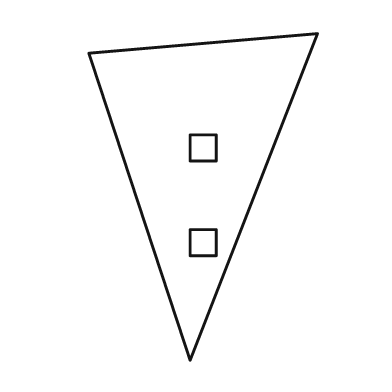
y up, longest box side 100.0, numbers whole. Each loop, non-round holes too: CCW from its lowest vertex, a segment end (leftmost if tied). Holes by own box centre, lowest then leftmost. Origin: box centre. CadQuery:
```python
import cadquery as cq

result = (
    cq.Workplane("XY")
    .moveTo(-4.0, -50.0)
    .lineTo(35.0, 50.0)
    .lineTo(-35.0, 44.0)
    .close()
    .moveTo(-4.0, -18.0)
    .lineTo(4.0, -18.0)
    .lineTo(4.0, -10.0)
    .lineTo(-4.0, -10.0)
    .close()
    .moveTo(-4.0, 11.0)
    .lineTo(4.0, 11.0)
    .lineTo(4.0, 19.0)
    .lineTo(-4.0, 19.0)
    .close()
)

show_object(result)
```